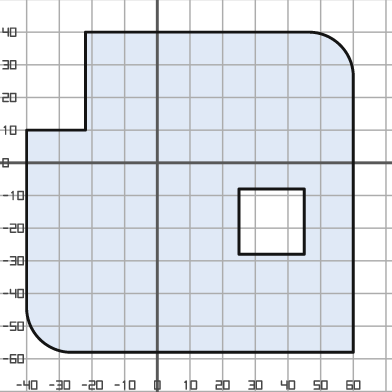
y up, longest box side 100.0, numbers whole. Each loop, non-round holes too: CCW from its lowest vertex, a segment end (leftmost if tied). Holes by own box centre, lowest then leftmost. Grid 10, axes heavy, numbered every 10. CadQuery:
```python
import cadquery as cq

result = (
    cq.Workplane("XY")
    .moveTo(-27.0, -58.0)
    .lineTo(60.0, -58.0)
    .lineTo(60.0, 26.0)
    .threePointArc((56.0, 36.0), (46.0, 40.0))
    .lineTo(-22.0, 40.0)
    .lineTo(-22.0, 10.0)
    .lineTo(-40.0, 10.0)
    .lineTo(-40.0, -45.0)
    .threePointArc((-36.0, -54.0), (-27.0, -58.0))
    .close()
    .moveTo(25.0, -28.0)
    .lineTo(45.0, -28.0)
    .lineTo(45.0, -8.0)
    .lineTo(25.0, -8.0)
    .close()
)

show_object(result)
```